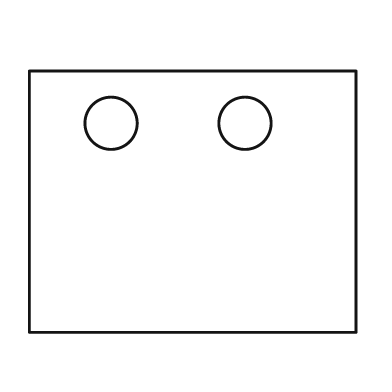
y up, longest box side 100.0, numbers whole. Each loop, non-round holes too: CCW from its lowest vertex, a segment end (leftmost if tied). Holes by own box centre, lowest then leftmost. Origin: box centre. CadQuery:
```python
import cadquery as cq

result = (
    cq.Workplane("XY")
    .moveTo(-50.0, -40.0)
    .lineTo(50.0, -40.0)
    .lineTo(50.0, 40.0)
    .lineTo(-50.0, 40.0)
    .close()
    .moveTo(-25.0, 24.0)
    .circle(8.0)
    .moveTo(16.0, 24.0)
    .circle(8.0)
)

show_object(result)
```